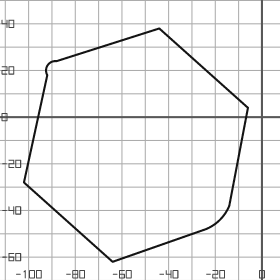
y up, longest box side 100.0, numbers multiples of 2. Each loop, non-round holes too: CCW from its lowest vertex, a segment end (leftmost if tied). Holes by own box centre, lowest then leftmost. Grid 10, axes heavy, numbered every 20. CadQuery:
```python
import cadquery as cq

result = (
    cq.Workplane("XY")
    .moveTo(-64.0, -62.0)
    .lineTo(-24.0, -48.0)
    .threePointArc((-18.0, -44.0), (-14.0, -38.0))
    .lineTo(-6.0, 4.0)
    .lineTo(-44.0, 38.0)
    .lineTo(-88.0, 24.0)
    .threePointArc((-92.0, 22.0), (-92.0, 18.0))
    .lineTo(-102.0, -28.0)
    .close()
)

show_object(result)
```